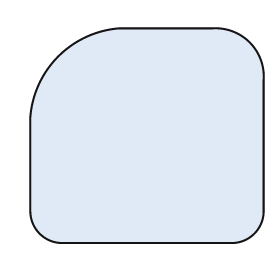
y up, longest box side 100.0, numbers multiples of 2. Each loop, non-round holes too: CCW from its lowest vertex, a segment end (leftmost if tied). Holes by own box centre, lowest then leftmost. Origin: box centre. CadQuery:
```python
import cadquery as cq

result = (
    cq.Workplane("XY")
    .moveTo(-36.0, -46.0)
    .lineTo(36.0, -46.0)
    .threePointArc((46.0, -42.0), (50.0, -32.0))
    .lineTo(50.0, 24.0)
    .threePointArc((44.0, 40.0), (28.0, 46.0))
    .lineTo(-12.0, 46.0)
    .threePointArc((-38.0, 34.0), (-50.0, 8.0))
    .lineTo(-50.0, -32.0)
    .threePointArc((-46.0, -42.0), (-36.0, -46.0))
    .close()
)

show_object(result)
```